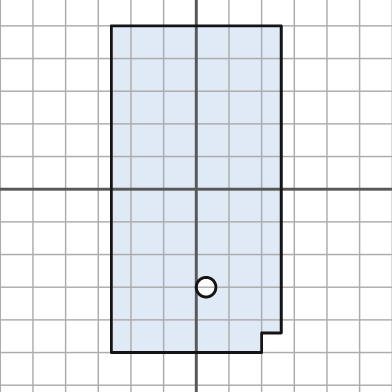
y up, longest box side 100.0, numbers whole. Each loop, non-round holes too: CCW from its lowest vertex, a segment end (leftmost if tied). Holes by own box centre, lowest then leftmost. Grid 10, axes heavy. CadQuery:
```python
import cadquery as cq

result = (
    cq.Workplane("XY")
    .moveTo(-26.0, -50.0)
    .lineTo(20.0, -50.0)
    .lineTo(20.0, -44.0)
    .lineTo(26.0, -44.0)
    .lineTo(26.0, 50.0)
    .lineTo(-26.0, 50.0)
    .close()
    .moveTo(3.0, -30.0)
    .circle(3.0)
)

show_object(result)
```